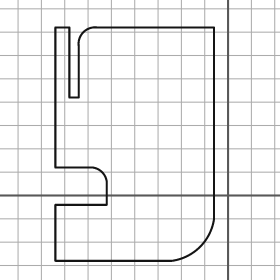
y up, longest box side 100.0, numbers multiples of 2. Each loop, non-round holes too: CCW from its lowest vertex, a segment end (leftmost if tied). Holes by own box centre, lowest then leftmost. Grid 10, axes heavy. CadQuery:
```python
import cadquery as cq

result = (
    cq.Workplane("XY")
    .moveTo(-74.0, -28.0)
    .lineTo(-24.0, -28.0)
    .threePointArc((-12.0, -22.0), (-6.0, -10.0))
    .lineTo(-6.0, 72.0)
    .lineTo(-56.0, 72.0)
    .threePointArc((-62.0, 70.0), (-64.0, 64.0))
    .lineTo(-64.0, 42.0)
    .lineTo(-68.0, 42.0)
    .lineTo(-68.0, 72.0)
    .lineTo(-74.0, 72.0)
    .lineTo(-74.0, 12.0)
    .lineTo(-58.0, 12.0)
    .threePointArc((-54.0, 10.0), (-52.0, 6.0))
    .lineTo(-52.0, -4.0)
    .lineTo(-74.0, -4.0)
    .close()
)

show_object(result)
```